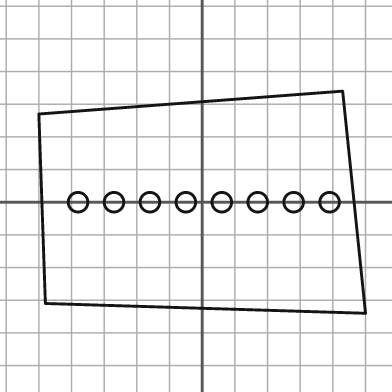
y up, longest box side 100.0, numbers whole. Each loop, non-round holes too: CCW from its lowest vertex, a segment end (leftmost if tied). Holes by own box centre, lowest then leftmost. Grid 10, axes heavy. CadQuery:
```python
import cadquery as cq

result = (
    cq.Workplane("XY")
    .moveTo(50.0, -34.0)
    .lineTo(43.0, 34.0)
    .lineTo(-50.0, 27.0)
    .lineTo(-48.0, -31.0)
    .close()
    .moveTo(-38.0, 0.0)
    .circle(3.0)
    .moveTo(-27.0, 0.0)
    .circle(3.0)
    .moveTo(-16.0, 0.0)
    .circle(3.0)
    .moveTo(-5.0, 0.0)
    .circle(3.0)
    .moveTo(6.0, 0.0)
    .circle(3.0)
    .moveTo(17.0, 0.0)
    .circle(3.0)
    .moveTo(28.0, 0.0)
    .circle(3.0)
    .moveTo(39.0, 0.0)
    .circle(3.0)
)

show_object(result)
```